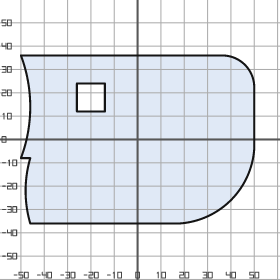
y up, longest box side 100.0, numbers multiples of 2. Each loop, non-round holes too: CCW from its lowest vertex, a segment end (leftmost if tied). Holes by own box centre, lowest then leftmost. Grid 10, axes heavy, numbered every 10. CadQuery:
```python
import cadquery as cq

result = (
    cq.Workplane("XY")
    .moveTo(-46.0, -36.0)
    .lineTo(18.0, -36.0)
    .threePointArc((40.0, -26.0), (50.0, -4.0))
    .lineTo(50.0, 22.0)
    .threePointArc((46.0, 32.0), (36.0, 36.0))
    .lineTo(-50.0, 36.0)
    .threePointArc((-46.0, 14.0), (-50.0, -8.0))
    .lineTo(-46.0, -8.0)
    .threePointArc((-48.0, -22.0), (-46.0, -36.0))
    .close()
    .moveTo(-26.0, 12.0)
    .lineTo(-14.0, 12.0)
    .lineTo(-14.0, 24.0)
    .lineTo(-26.0, 24.0)
    .close()
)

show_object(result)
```